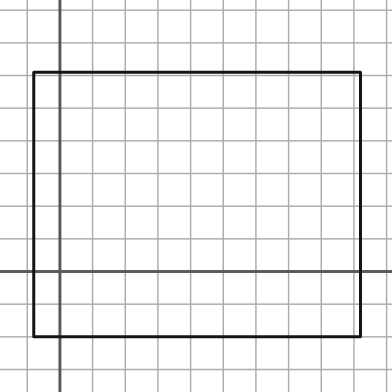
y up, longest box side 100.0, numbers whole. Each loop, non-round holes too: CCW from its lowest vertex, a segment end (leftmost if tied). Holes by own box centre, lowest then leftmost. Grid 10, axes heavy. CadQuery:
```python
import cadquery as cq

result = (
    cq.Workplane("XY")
    .moveTo(-8.0, -20.0)
    .lineTo(92.0, -20.0)
    .lineTo(92.0, 61.0)
    .lineTo(-8.0, 61.0)
    .close()
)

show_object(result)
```